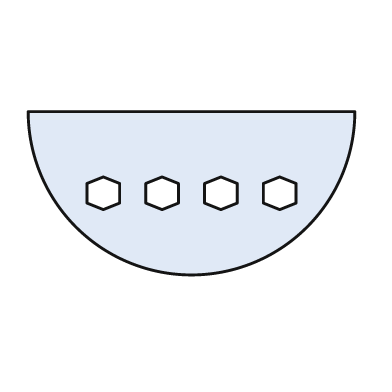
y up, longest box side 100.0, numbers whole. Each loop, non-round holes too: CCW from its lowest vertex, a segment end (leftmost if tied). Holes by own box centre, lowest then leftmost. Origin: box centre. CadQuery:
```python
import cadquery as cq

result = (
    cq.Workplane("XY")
    .moveTo(-50.0, 25.0)
    .threePointArc((0.0, -25.0), (50.0, 25.0))
    .close()
    .moveTo(-27.0, -5.0)
    .lineTo(-22.0, -3.0)
    .lineTo(-22.0, 3.0)
    .lineTo(-27.0, 5.0)
    .lineTo(-32.0, 3.0)
    .lineTo(-32.0, -3.0)
    .close()
    .moveTo(-9.0, -5.0)
    .lineTo(-4.0, -3.0)
    .lineTo(-4.0, 3.0)
    .lineTo(-9.0, 5.0)
    .lineTo(-14.0, 3.0)
    .lineTo(-14.0, -3.0)
    .close()
    .moveTo(9.0, -5.0)
    .lineTo(14.0, -3.0)
    .lineTo(14.0, 3.0)
    .lineTo(9.0, 5.0)
    .lineTo(4.0, 3.0)
    .lineTo(4.0, -3.0)
    .close()
    .moveTo(27.0, -5.0)
    .lineTo(32.0, -3.0)
    .lineTo(32.0, 3.0)
    .lineTo(27.0, 5.0)
    .lineTo(22.0, 3.0)
    .lineTo(22.0, -3.0)
    .close()
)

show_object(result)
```